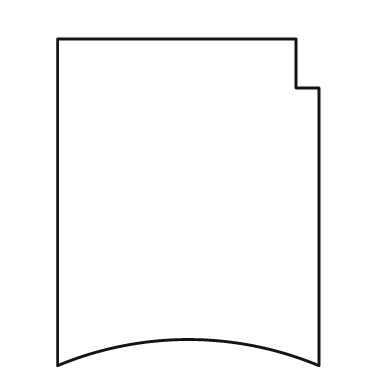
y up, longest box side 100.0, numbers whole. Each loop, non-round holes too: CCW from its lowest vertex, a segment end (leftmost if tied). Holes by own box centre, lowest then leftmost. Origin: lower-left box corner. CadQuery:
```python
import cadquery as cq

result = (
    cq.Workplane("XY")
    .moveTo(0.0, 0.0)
    .threePointArc((40.0, 8.0), (80.0, 0.0))
    .lineTo(80.0, 85.0)
    .lineTo(73.0, 85.0)
    .lineTo(73.0, 100.0)
    .lineTo(0.0, 100.0)
    .close()
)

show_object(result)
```